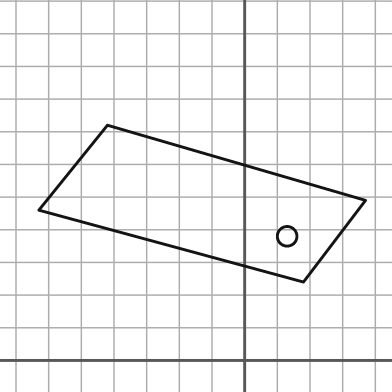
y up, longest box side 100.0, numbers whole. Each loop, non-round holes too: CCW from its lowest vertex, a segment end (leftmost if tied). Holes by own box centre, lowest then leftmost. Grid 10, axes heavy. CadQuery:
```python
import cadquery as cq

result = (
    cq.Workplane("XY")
    .moveTo(18.0, 24.0)
    .lineTo(37.0, 49.0)
    .lineTo(-42.0, 72.0)
    .lineTo(-63.0, 46.0)
    .close()
    .moveTo(13.0, 38.0)
    .circle(3.0)
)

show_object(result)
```